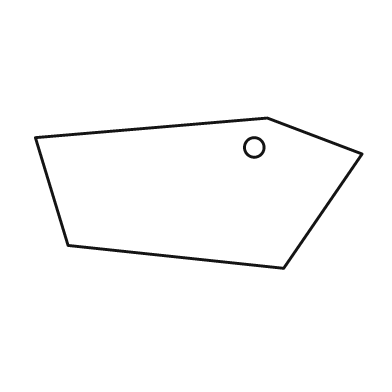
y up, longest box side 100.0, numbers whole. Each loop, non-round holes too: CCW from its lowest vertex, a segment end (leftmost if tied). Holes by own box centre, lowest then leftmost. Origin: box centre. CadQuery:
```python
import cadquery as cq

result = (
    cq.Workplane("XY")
    .moveTo(26.0, -23.0)
    .lineTo(50.0, 12.0)
    .lineTo(21.0, 23.0)
    .lineTo(-50.0, 17.0)
    .lineTo(-40.0, -16.0)
    .close()
    .moveTo(17.0, 14.0)
    .circle(3.0)
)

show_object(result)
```